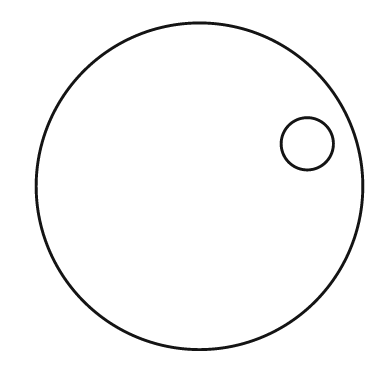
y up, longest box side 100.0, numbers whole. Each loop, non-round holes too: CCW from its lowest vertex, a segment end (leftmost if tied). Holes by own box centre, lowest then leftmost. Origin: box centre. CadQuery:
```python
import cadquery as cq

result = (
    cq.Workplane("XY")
    .moveTo(0.0, 0.0)
    .circle(50.0)
    .moveTo(33.0, 13.0)
    .circle(8.0)
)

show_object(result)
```